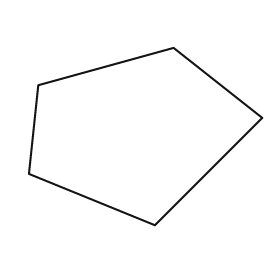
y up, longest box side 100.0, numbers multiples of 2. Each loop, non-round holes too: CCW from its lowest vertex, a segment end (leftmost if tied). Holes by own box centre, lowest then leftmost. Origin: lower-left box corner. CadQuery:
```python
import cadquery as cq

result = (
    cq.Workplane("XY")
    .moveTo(54.0, 0.0)
    .lineTo(100.0, 46.0)
    .lineTo(62.0, 76.0)
    .lineTo(4.0, 60.0)
    .lineTo(0.0, 22.0)
    .close()
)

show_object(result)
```